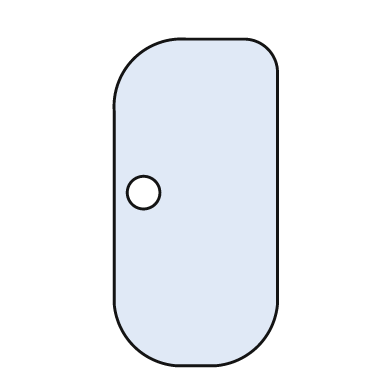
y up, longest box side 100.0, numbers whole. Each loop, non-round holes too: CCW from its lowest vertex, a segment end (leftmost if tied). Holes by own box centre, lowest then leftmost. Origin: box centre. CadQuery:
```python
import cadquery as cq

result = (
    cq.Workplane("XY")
    .moveTo(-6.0, -50.0)
    .lineTo(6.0, -50.0)
    .threePointArc((19.0, -44.0), (25.0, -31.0))
    .lineTo(25.0, 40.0)
    .threePointArc((22.0, 47.0), (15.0, 50.0))
    .lineTo(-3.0, 50.0)
    .threePointArc((-19.0, 44.0), (-25.0, 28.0))
    .lineTo(-25.0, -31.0)
    .threePointArc((-19.0, -44.0), (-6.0, -50.0))
    .close()
    .moveTo(-16.0, 3.0)
    .circle(5.0)
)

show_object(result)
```